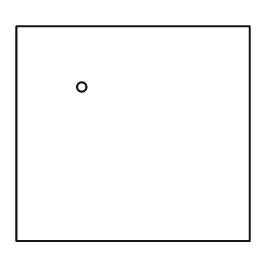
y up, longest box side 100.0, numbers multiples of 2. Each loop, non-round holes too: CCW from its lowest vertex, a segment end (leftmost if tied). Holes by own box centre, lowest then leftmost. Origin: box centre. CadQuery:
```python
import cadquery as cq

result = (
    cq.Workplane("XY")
    .moveTo(-50.0, -46.0)
    .lineTo(50.0, -46.0)
    .lineTo(50.0, 46.0)
    .lineTo(-50.0, 46.0)
    .close()
    .moveTo(-22.0, 20.0)
    .circle(2.0)
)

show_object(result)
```